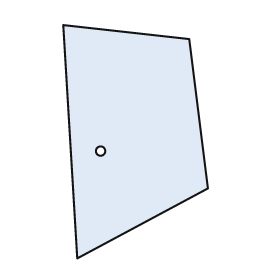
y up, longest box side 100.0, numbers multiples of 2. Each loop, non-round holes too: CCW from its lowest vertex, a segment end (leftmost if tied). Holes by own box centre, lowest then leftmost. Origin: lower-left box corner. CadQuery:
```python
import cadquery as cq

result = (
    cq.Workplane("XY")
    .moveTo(6.0, 0.0)
    .lineTo(62.0, 30.0)
    .lineTo(54.0, 94.0)
    .lineTo(0.0, 100.0)
    .close()
    .moveTo(16.0, 46.0)
    .circle(2.0)
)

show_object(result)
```